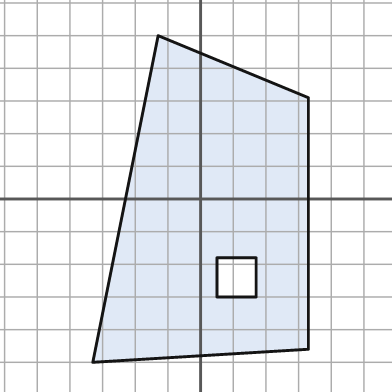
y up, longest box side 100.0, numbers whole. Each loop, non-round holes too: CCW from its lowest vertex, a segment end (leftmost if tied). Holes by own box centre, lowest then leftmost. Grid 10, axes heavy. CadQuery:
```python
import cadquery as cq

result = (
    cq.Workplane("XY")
    .moveTo(-33.0, -50.0)
    .lineTo(33.0, -46.0)
    .lineTo(33.0, 31.0)
    .lineTo(-13.0, 50.0)
    .close()
    .moveTo(5.0, -30.0)
    .lineTo(17.0, -30.0)
    .lineTo(17.0, -18.0)
    .lineTo(5.0, -18.0)
    .close()
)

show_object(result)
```